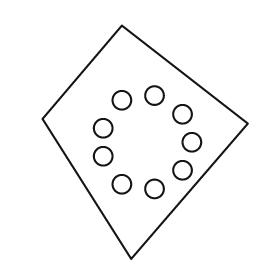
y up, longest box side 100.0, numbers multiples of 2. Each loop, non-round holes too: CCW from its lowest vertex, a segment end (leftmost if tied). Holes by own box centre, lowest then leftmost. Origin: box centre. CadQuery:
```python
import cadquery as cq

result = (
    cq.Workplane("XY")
    .moveTo(-6.0, -50.0)
    .lineTo(44.0, 8.0)
    .lineTo(-10.0, 50.0)
    .lineTo(-44.0, 10.0)
    .close()
    .moveTo(4.0, -20.0)
    .circle(4.0)
    .moveTo(-10.0, -18.0)
    .circle(4.0)
    .moveTo(16.0, -12.0)
    .circle(4.0)
    .moveTo(-18.0, -6.0)
    .circle(4.0)
    .moveTo(20.0, 0.0)
    .circle(4.0)
    .moveTo(-18.0, 6.0)
    .circle(4.0)
    .moveTo(16.0, 12.0)
    .circle(4.0)
    .moveTo(-10.0, 18.0)
    .circle(4.0)
    .moveTo(4.0, 20.0)
    .circle(4.0)
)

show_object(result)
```